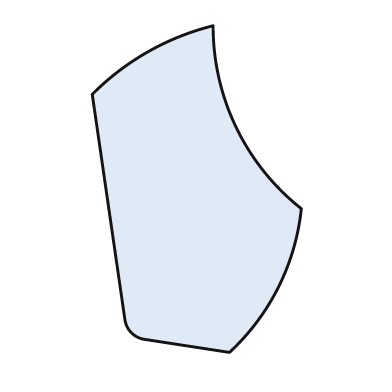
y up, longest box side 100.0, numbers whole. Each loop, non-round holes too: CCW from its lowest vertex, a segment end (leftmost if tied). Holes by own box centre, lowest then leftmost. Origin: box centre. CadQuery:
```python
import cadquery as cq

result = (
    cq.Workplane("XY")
    .moveTo(10.0, -50.0)
    .threePointArc((25.0, -30.0), (32.0, -6.0))
    .threePointArc((12.0, 19.0), (5.0, 50.0))
    .threePointArc((-15.0, 42.0), (-32.0, 29.0))
    .lineTo(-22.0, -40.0)
    .threePointArc((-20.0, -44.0), (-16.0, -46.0))
    .close()
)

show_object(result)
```